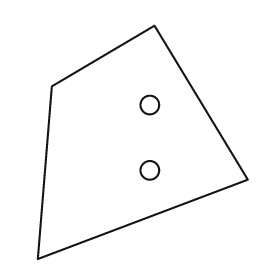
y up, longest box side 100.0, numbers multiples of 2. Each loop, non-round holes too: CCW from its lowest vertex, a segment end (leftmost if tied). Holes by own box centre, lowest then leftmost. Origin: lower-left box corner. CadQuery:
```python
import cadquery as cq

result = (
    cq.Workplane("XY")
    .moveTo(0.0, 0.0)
    .lineTo(90.0, 34.0)
    .lineTo(50.0, 100.0)
    .lineTo(6.0, 74.0)
    .close()
    .moveTo(48.0, 38.0)
    .circle(4.0)
    .moveTo(48.0, 66.0)
    .circle(4.0)
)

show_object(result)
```